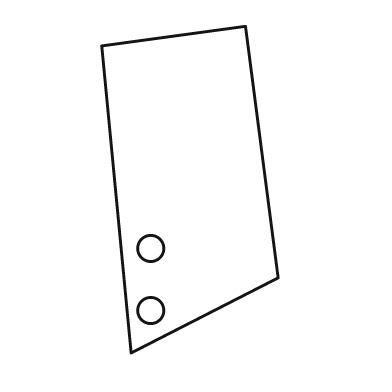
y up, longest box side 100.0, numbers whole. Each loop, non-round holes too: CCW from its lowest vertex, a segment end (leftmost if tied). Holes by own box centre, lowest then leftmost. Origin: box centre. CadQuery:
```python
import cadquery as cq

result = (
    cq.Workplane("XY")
    .moveTo(-18.0, -50.0)
    .lineTo(27.0, -27.0)
    .lineTo(17.0, 50.0)
    .lineTo(-27.0, 44.0)
    .close()
    .moveTo(-12.0, -37.0)
    .circle(4.0)
    .moveTo(-12.0, -18.0)
    .circle(4.0)
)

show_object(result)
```